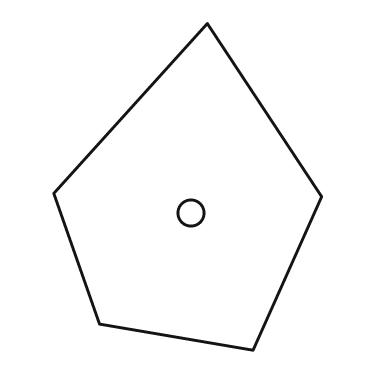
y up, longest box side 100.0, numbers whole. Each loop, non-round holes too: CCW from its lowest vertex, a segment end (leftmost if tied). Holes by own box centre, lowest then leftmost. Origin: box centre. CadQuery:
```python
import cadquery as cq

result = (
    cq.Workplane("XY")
    .moveTo(20.0, -50.0)
    .lineTo(41.0, -3.0)
    .lineTo(6.0, 50.0)
    .lineTo(-41.0, -2.0)
    .lineTo(-27.0, -42.0)
    .close()
    .moveTo(1.0, -8.0)
    .circle(4.0)
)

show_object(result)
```